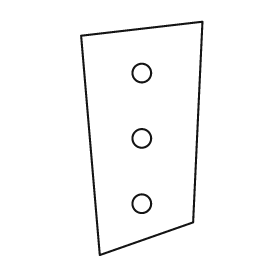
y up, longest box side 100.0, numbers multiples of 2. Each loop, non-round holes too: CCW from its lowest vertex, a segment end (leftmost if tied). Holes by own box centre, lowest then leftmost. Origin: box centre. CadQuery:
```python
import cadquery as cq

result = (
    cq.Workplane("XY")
    .moveTo(-18.0, -50.0)
    .lineTo(22.0, -36.0)
    .lineTo(26.0, 50.0)
    .lineTo(-26.0, 44.0)
    .close()
    .moveTo(0.0, -28.0)
    .circle(4.0)
    .moveTo(0.0, 0.0)
    .circle(4.0)
    .moveTo(0.0, 28.0)
    .circle(4.0)
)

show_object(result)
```